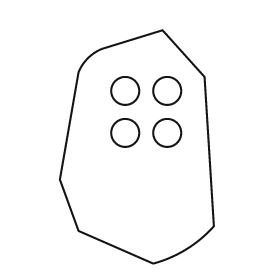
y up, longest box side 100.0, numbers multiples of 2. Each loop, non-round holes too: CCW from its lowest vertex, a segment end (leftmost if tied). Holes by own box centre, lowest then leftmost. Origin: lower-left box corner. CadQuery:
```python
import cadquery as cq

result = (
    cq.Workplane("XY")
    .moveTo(40.0, 0.0)
    .threePointArc((54.0, 6.0), (66.0, 16.0))
    .lineTo(62.0, 80.0)
    .lineTo(44.0, 100.0)
    .lineTo(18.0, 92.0)
    .threePointArc((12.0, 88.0), (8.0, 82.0))
    .lineTo(0.0, 36.0)
    .lineTo(8.0, 14.0)
    .close()
    .moveTo(28.0, 56.0)
    .circle(6.0)
    .moveTo(46.0, 56.0)
    .circle(6.0)
    .moveTo(28.0, 74.0)
    .circle(6.0)
    .moveTo(46.0, 74.0)
    .circle(6.0)
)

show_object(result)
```